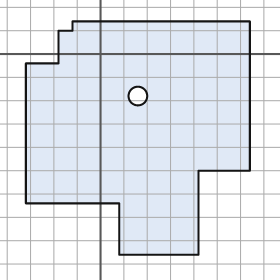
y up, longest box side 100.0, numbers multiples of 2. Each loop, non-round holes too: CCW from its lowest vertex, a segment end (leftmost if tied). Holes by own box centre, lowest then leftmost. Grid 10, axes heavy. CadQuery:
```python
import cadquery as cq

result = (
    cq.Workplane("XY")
    .moveTo(8.0, -86.0)
    .lineTo(42.0, -86.0)
    .lineTo(42.0, -50.0)
    .lineTo(64.0, -50.0)
    .lineTo(64.0, 14.0)
    .lineTo(-12.0, 14.0)
    .lineTo(-12.0, 10.0)
    .lineTo(-18.0, 10.0)
    .lineTo(-18.0, -4.0)
    .lineTo(-32.0, -4.0)
    .lineTo(-32.0, -64.0)
    .lineTo(8.0, -64.0)
    .close()
    .moveTo(16.0, -18.0)
    .circle(4.0)
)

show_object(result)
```